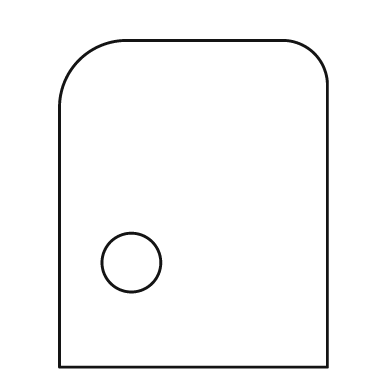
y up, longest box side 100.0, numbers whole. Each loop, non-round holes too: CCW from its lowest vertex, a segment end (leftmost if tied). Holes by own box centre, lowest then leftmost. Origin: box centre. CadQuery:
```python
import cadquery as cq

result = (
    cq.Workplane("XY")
    .moveTo(-41.0, -50.0)
    .lineTo(41.0, -50.0)
    .lineTo(41.0, 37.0)
    .threePointArc((37.0, 46.0), (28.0, 50.0))
    .lineTo(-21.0, 50.0)
    .threePointArc((-35.0, 44.0), (-41.0, 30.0))
    .close()
    .moveTo(-19.0, -18.0)
    .circle(9.0)
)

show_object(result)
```